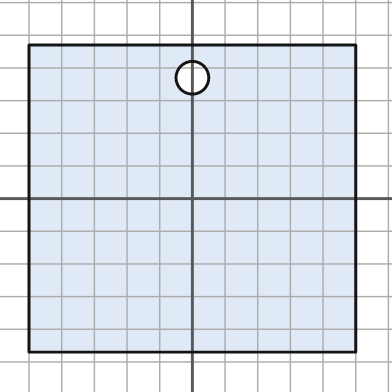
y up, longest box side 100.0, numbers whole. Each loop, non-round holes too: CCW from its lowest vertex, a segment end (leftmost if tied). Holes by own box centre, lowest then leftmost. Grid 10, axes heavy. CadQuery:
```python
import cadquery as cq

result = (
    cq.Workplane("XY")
    .moveTo(-50.0, -47.0)
    .lineTo(50.0, -47.0)
    .lineTo(50.0, 47.0)
    .lineTo(-50.0, 47.0)
    .close()
    .moveTo(0.0, 37.0)
    .circle(5.0)
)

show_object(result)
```